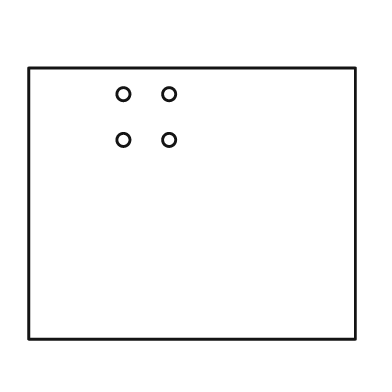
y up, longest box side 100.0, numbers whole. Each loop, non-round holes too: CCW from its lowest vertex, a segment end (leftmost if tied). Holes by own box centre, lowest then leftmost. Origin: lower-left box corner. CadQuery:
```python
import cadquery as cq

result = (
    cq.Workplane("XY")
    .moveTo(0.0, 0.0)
    .lineTo(100.0, 0.0)
    .lineTo(100.0, 83.0)
    .lineTo(0.0, 83.0)
    .close()
    .moveTo(29.0, 61.0)
    .circle(2.0)
    .moveTo(43.0, 61.0)
    .circle(2.0)
    .moveTo(29.0, 75.0)
    .circle(2.0)
    .moveTo(43.0, 75.0)
    .circle(2.0)
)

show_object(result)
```